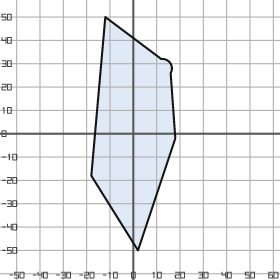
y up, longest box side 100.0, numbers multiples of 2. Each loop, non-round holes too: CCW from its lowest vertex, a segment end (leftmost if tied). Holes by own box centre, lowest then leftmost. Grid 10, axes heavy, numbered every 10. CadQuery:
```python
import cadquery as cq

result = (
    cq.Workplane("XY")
    .moveTo(2.0, -50.0)
    .lineTo(18.0, -2.0)
    .lineTo(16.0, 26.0)
    .threePointArc((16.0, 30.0), (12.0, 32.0))
    .lineTo(-12.0, 50.0)
    .lineTo(-18.0, -18.0)
    .close()
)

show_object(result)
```